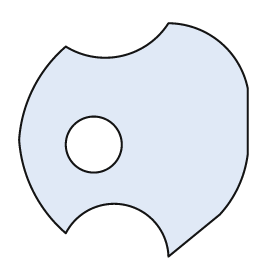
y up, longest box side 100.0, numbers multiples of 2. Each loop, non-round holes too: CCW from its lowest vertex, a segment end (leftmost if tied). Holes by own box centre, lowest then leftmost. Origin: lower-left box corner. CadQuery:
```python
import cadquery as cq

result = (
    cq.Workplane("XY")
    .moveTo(64.0, 0.0)
    .lineTo(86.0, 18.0)
    .threePointArc((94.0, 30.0), (98.0, 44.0))
    .lineTo(98.0, 72.0)
    .threePointArc((86.0, 92.0), (64.0, 100.0))
    .threePointArc((44.0, 86.0), (20.0, 90.0))
    .threePointArc((6.0, 72.0), (0.0, 50.0))
    .threePointArc((6.0, 28.0), (20.0, 10.0))
    .threePointArc((46.0, 22.0), (64.0, 0.0))
    .close()
    .moveTo(32.0, 48.0)
    .circle(12.0)
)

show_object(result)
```